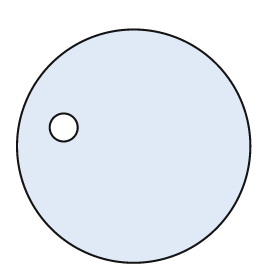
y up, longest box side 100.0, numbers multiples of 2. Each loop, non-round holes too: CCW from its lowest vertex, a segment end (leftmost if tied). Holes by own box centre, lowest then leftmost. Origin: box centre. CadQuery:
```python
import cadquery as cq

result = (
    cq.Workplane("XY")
    .moveTo(0.0, 0.0)
    .circle(50.0)
    .moveTo(-30.0, 8.0)
    .circle(6.0)
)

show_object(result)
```